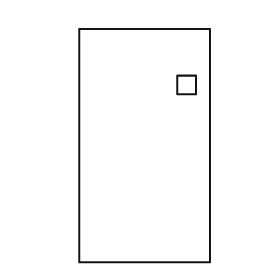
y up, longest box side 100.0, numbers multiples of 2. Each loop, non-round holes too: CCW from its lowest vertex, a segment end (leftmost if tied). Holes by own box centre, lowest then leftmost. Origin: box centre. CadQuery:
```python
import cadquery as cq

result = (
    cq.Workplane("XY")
    .moveTo(-28.0, -50.0)
    .lineTo(28.0, -50.0)
    .lineTo(28.0, 50.0)
    .lineTo(-28.0, 50.0)
    .close()
    .moveTo(14.0, 22.0)
    .lineTo(22.0, 22.0)
    .lineTo(22.0, 30.0)
    .lineTo(14.0, 30.0)
    .close()
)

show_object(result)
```